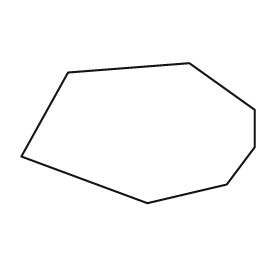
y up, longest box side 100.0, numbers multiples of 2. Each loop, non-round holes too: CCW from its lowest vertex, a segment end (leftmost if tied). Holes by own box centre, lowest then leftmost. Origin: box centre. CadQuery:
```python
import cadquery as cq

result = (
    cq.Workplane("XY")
    .moveTo(4.0, -30.0)
    .lineTo(38.0, -22.0)
    .lineTo(50.0, -6.0)
    .lineTo(50.0, 10.0)
    .lineTo(22.0, 30.0)
    .lineTo(-30.0, 26.0)
    .lineTo(-50.0, -10.0)
    .close()
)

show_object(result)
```